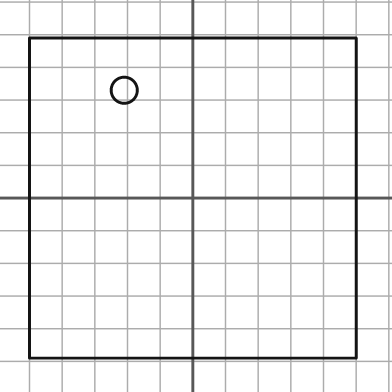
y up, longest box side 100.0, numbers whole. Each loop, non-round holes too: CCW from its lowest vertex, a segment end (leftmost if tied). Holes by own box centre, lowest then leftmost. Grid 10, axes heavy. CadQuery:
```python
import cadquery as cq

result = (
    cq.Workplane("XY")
    .moveTo(-50.0, -49.0)
    .lineTo(50.0, -49.0)
    .lineTo(50.0, 49.0)
    .lineTo(-50.0, 49.0)
    .close()
    .moveTo(-21.0, 33.0)
    .circle(4.0)
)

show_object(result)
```